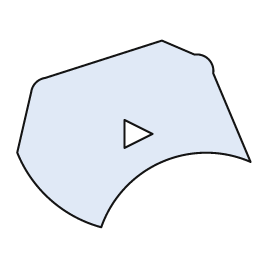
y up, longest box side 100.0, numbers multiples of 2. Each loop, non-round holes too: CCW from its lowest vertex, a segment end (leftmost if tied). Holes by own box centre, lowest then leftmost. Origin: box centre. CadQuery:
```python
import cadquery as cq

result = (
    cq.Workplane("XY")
    .moveTo(-14.0, -40.0)
    .threePointArc((12.0, -12.0), (50.0, -12.0))
    .lineTo(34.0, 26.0)
    .threePointArc((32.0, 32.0), (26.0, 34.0))
    .lineTo(12.0, 40.0)
    .lineTo(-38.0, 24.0)
    .threePointArc((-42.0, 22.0), (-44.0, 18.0))
    .lineTo(-50.0, -8.0)
    .threePointArc((-36.0, -28.0), (-14.0, -40.0))
    .close()
    .moveTo(-4.0, -6.0)
    .lineTo(8.0, 0.0)
    .lineTo(-4.0, 6.0)
    .close()
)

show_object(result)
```